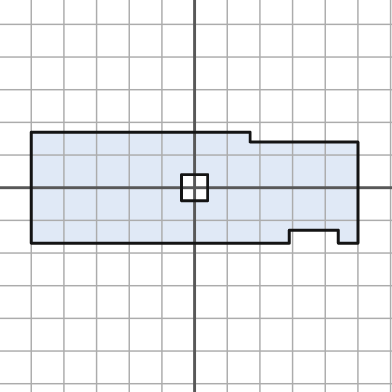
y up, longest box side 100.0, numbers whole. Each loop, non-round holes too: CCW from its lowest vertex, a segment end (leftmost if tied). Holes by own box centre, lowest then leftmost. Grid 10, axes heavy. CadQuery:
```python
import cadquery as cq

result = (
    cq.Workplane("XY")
    .moveTo(-50.0, -17.0)
    .lineTo(29.0, -17.0)
    .lineTo(29.0, -13.0)
    .lineTo(44.0, -13.0)
    .lineTo(44.0, -17.0)
    .lineTo(50.0, -17.0)
    .lineTo(50.0, 14.0)
    .lineTo(17.0, 14.0)
    .lineTo(17.0, 17.0)
    .lineTo(-50.0, 17.0)
    .close()
    .moveTo(-4.0, -4.0)
    .lineTo(4.0, -4.0)
    .lineTo(4.0, 4.0)
    .lineTo(-4.0, 4.0)
    .close()
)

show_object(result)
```